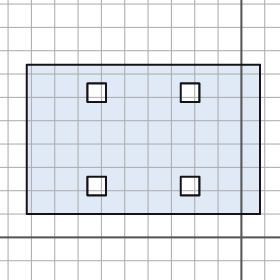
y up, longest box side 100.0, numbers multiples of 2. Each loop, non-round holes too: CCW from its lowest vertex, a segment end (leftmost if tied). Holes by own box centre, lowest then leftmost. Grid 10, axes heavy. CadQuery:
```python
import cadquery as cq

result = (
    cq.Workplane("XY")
    .moveTo(-92.0, 10.0)
    .lineTo(8.0, 10.0)
    .lineTo(8.0, 74.0)
    .lineTo(-92.0, 74.0)
    .close()
    .moveTo(-66.0, 18.0)
    .lineTo(-58.0, 18.0)
    .lineTo(-58.0, 26.0)
    .lineTo(-66.0, 26.0)
    .close()
    .moveTo(-26.0, 18.0)
    .lineTo(-18.0, 18.0)
    .lineTo(-18.0, 26.0)
    .lineTo(-26.0, 26.0)
    .close()
    .moveTo(-66.0, 58.0)
    .lineTo(-58.0, 58.0)
    .lineTo(-58.0, 66.0)
    .lineTo(-66.0, 66.0)
    .close()
    .moveTo(-26.0, 58.0)
    .lineTo(-18.0, 58.0)
    .lineTo(-18.0, 66.0)
    .lineTo(-26.0, 66.0)
    .close()
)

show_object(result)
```